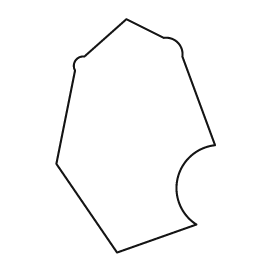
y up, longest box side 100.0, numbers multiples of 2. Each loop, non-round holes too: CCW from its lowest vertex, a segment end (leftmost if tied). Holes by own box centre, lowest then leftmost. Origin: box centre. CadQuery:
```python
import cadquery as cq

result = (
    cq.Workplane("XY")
    .moveTo(-8.0, -50.0)
    .lineTo(26.0, -38.0)
    .threePointArc((18.0, -18.0), (34.0, -4.0))
    .lineTo(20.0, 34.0)
    .threePointArc((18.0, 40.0), (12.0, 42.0))
    .lineTo(-4.0, 50.0)
    .lineTo(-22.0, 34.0)
    .threePointArc((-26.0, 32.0), (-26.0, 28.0))
    .lineTo(-34.0, -12.0)
    .close()
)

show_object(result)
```